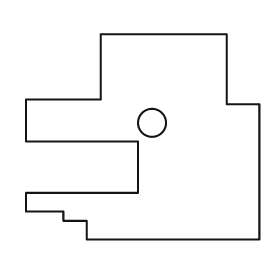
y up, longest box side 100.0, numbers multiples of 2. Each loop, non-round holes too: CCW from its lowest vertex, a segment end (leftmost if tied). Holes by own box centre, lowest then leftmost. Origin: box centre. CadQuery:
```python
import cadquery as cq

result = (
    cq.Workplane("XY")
    .moveTo(-24.0, -44.0)
    .lineTo(50.0, -44.0)
    .lineTo(50.0, 14.0)
    .lineTo(36.0, 14.0)
    .lineTo(36.0, 44.0)
    .lineTo(-18.0, 44.0)
    .lineTo(-18.0, 16.0)
    .lineTo(-50.0, 16.0)
    .lineTo(-50.0, -2.0)
    .lineTo(-2.0, -2.0)
    .lineTo(-2.0, -24.0)
    .lineTo(-50.0, -24.0)
    .lineTo(-50.0, -32.0)
    .lineTo(-34.0, -32.0)
    .lineTo(-34.0, -36.0)
    .lineTo(-24.0, -36.0)
    .close()
    .moveTo(4.0, 6.0)
    .circle(6.0)
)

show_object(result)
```